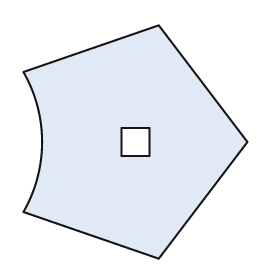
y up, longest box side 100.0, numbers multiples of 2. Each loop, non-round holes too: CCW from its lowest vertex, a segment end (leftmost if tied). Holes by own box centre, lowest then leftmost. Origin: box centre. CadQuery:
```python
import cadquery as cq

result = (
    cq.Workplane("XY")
    .moveTo(10.0, -50.0)
    .lineTo(48.0, 0.0)
    .lineTo(10.0, 50.0)
    .lineTo(-48.0, 30.0)
    .threePointArc((-40.0, 0.0), (-48.0, -30.0))
    .close()
    .moveTo(-6.0, -6.0)
    .lineTo(6.0, -6.0)
    .lineTo(6.0, 6.0)
    .lineTo(-6.0, 6.0)
    .close()
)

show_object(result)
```